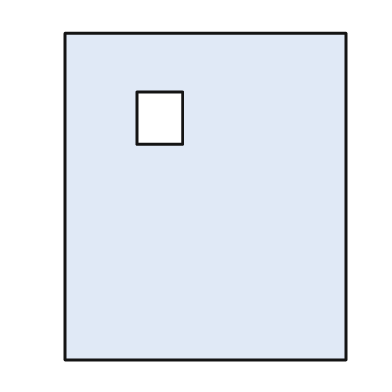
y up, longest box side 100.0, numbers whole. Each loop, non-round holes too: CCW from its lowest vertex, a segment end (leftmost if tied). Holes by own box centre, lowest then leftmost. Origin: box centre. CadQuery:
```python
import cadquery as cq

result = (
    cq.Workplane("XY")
    .moveTo(-43.0, -50.0)
    .lineTo(43.0, -50.0)
    .lineTo(43.0, 50.0)
    .lineTo(-43.0, 50.0)
    .close()
    .moveTo(-21.0, 16.0)
    .lineTo(-7.0, 16.0)
    .lineTo(-7.0, 32.0)
    .lineTo(-21.0, 32.0)
    .close()
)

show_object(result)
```